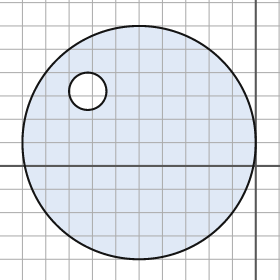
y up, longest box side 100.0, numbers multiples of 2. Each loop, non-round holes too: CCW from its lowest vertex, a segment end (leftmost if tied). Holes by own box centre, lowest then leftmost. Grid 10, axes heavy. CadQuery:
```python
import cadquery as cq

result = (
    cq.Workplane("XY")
    .moveTo(-50.0, 10.0)
    .circle(50.0)
    .moveTo(-72.0, 32.0)
    .circle(8.0)
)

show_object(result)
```